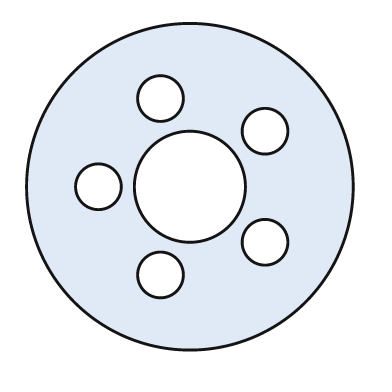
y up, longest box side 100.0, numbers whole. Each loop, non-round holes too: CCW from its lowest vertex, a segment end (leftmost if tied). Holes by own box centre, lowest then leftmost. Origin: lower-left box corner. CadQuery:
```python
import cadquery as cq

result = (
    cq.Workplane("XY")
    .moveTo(50.0, 50.0)
    .circle(50.0)
    .moveTo(41.0, 23.0)
    .circle(7.0)
    .moveTo(73.0, 33.0)
    .circle(7.0)
    .moveTo(22.0, 50.0)
    .circle(7.0)
    .moveTo(50.0, 50.0)
    .circle(17.0)
    .moveTo(73.0, 67.0)
    .circle(7.0)
    .moveTo(41.0, 77.0)
    .circle(7.0)
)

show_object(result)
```